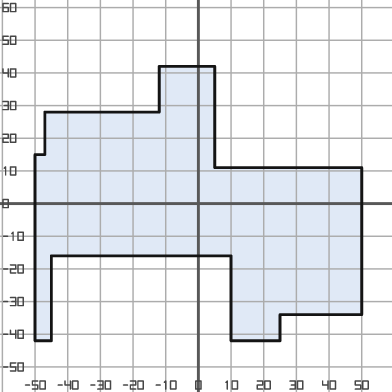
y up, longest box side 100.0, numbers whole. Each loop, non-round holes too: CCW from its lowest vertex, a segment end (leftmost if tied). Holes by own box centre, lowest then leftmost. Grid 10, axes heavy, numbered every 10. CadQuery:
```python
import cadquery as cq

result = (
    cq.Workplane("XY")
    .moveTo(-50.0, -42.0)
    .lineTo(-45.0, -42.0)
    .lineTo(-45.0, -16.0)
    .lineTo(10.0, -16.0)
    .lineTo(10.0, -42.0)
    .lineTo(25.0, -42.0)
    .lineTo(25.0, -34.0)
    .lineTo(50.0, -34.0)
    .lineTo(50.0, 11.0)
    .lineTo(5.0, 11.0)
    .lineTo(5.0, 42.0)
    .lineTo(-12.0, 42.0)
    .lineTo(-12.0, 28.0)
    .lineTo(-47.0, 28.0)
    .lineTo(-47.0, 15.0)
    .lineTo(-50.0, 15.0)
    .close()
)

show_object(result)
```